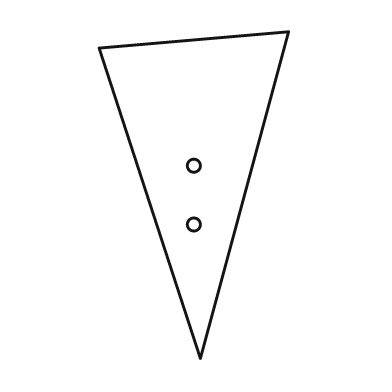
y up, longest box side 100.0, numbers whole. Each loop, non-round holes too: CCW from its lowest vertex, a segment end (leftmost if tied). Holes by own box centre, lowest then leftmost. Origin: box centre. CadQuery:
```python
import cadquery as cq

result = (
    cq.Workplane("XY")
    .moveTo(2.0, -50.0)
    .lineTo(29.0, 50.0)
    .lineTo(-29.0, 45.0)
    .close()
    .moveTo(0.0, -9.0)
    .circle(2.0)
    .moveTo(0.0, 9.0)
    .circle(2.0)
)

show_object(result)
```